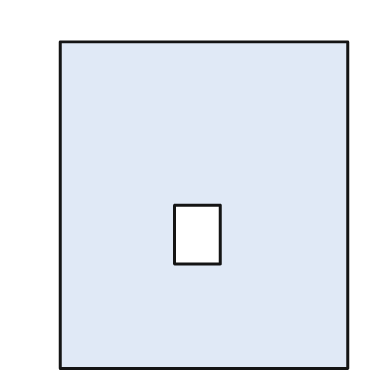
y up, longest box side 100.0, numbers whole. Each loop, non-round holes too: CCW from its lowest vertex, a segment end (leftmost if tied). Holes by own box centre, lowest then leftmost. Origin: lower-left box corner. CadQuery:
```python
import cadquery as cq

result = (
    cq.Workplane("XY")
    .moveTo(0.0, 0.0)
    .lineTo(88.0, 0.0)
    .lineTo(88.0, 100.0)
    .lineTo(0.0, 100.0)
    .close()
    .moveTo(35.0, 32.0)
    .lineTo(49.0, 32.0)
    .lineTo(49.0, 50.0)
    .lineTo(35.0, 50.0)
    .close()
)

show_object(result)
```